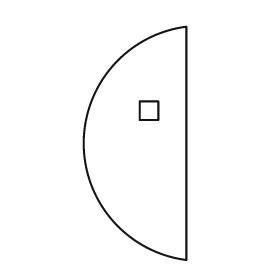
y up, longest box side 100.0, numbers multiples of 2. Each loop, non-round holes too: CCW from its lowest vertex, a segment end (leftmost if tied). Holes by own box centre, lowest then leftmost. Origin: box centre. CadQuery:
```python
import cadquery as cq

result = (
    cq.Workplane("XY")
    .moveTo(22.0, -50.0)
    .lineTo(22.0, 50.0)
    .threePointArc((-22.0, 0.0), (22.0, -50.0))
    .close()
    .moveTo(2.0, 10.0)
    .lineTo(10.0, 10.0)
    .lineTo(10.0, 18.0)
    .lineTo(2.0, 18.0)
    .close()
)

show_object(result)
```